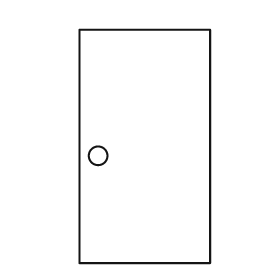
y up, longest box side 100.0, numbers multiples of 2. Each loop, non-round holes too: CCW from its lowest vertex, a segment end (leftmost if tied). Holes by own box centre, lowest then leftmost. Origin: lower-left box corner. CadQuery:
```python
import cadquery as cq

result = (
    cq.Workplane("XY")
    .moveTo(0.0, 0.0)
    .lineTo(56.0, 0.0)
    .lineTo(56.0, 100.0)
    .lineTo(0.0, 100.0)
    .close()
    .moveTo(8.0, 46.0)
    .circle(4.0)
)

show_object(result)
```